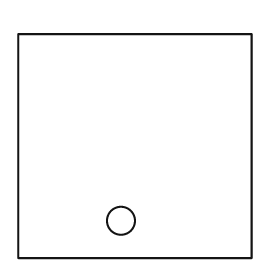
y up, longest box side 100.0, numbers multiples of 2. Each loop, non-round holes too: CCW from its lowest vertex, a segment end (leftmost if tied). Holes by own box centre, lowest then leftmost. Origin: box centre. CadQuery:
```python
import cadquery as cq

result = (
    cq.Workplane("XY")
    .moveTo(-50.0, -48.0)
    .lineTo(50.0, -48.0)
    .lineTo(50.0, 48.0)
    .lineTo(-50.0, 48.0)
    .close()
    .moveTo(-6.0, -32.0)
    .circle(6.0)
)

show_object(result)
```